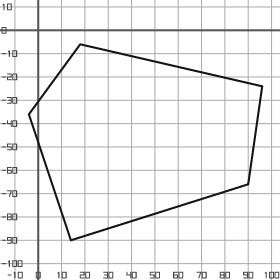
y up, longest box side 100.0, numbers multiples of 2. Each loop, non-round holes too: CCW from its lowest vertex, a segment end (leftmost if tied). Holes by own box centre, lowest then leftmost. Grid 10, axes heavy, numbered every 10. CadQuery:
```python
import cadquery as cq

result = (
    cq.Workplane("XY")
    .moveTo(14.0, -90.0)
    .lineTo(90.0, -66.0)
    .lineTo(96.0, -24.0)
    .lineTo(18.0, -6.0)
    .lineTo(-4.0, -36.0)
    .close()
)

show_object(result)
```